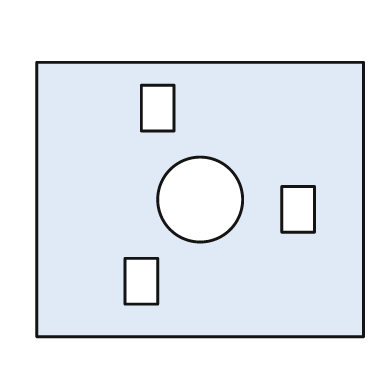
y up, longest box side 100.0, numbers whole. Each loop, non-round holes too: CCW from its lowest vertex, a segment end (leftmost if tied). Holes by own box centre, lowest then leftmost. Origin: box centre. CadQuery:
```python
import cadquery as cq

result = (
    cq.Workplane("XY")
    .moveTo(-50.0, -42.0)
    .lineTo(50.0, -42.0)
    .lineTo(50.0, 42.0)
    .lineTo(-50.0, 42.0)
    .close()
    .moveTo(-23.0, -32.0)
    .lineTo(-13.0, -32.0)
    .lineTo(-13.0, -18.0)
    .lineTo(-23.0, -18.0)
    .close()
    .moveTo(25.0, -10.0)
    .lineTo(35.0, -10.0)
    .lineTo(35.0, 4.0)
    .lineTo(25.0, 4.0)
    .close()
    .moveTo(0.0, 0.0)
    .circle(13.0)
    .moveTo(-18.0, 21.0)
    .lineTo(-8.0, 21.0)
    .lineTo(-8.0, 35.0)
    .lineTo(-18.0, 35.0)
    .close()
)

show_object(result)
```